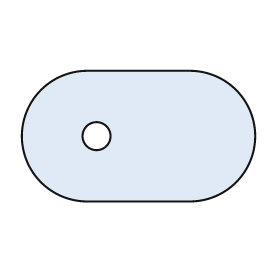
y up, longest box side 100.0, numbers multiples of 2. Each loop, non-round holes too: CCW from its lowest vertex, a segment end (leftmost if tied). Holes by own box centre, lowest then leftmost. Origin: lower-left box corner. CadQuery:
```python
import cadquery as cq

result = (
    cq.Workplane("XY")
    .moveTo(28.0, 0.0)
    .lineTo(72.0, 0.0)
    .threePointArc((100.0, 28.0), (72.0, 56.0))
    .lineTo(28.0, 56.0)
    .threePointArc((0.0, 28.0), (28.0, 0.0))
    .close()
    .moveTo(32.0, 28.0)
    .circle(6.0)
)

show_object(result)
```